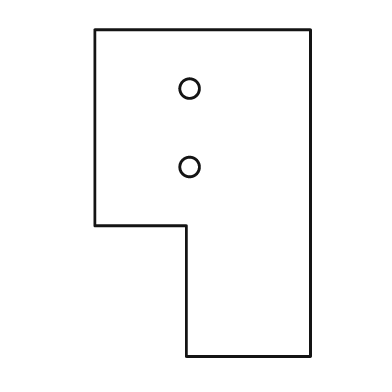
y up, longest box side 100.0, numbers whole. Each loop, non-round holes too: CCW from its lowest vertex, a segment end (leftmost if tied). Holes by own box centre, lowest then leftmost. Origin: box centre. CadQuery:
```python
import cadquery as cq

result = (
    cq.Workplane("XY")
    .moveTo(-5.0, -50.0)
    .lineTo(33.0, -50.0)
    .lineTo(33.0, 50.0)
    .lineTo(-33.0, 50.0)
    .lineTo(-33.0, -10.0)
    .lineTo(-5.0, -10.0)
    .close()
    .moveTo(-4.0, 8.0)
    .circle(3.0)
    .moveTo(-4.0, 32.0)
    .circle(3.0)
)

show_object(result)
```